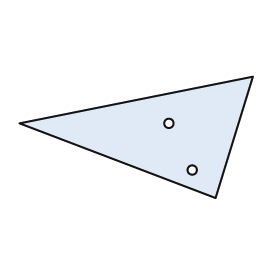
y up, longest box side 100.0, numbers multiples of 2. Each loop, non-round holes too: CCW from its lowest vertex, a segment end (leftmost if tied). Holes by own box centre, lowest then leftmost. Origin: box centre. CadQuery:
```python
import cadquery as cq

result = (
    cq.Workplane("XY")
    .moveTo(34.0, -26.0)
    .lineTo(50.0, 26.0)
    .lineTo(-50.0, 6.0)
    .close()
    .moveTo(24.0, -14.0)
    .circle(2.0)
    .moveTo(14.0, 6.0)
    .circle(2.0)
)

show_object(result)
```